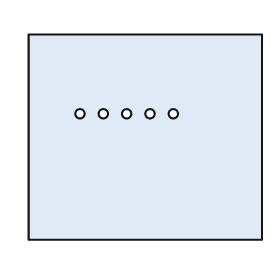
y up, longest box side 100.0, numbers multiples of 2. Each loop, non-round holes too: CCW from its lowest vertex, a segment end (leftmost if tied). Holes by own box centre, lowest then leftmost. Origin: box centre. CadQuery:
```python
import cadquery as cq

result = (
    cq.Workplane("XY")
    .moveTo(-50.0, -44.0)
    .lineTo(50.0, -44.0)
    .lineTo(50.0, 44.0)
    .lineTo(-50.0, 44.0)
    .close()
    .moveTo(-28.0, 10.0)
    .circle(2.0)
    .moveTo(-18.0, 10.0)
    .circle(2.0)
    .moveTo(-8.0, 10.0)
    .circle(2.0)
    .moveTo(2.0, 10.0)
    .circle(2.0)
    .moveTo(12.0, 10.0)
    .circle(2.0)
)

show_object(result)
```